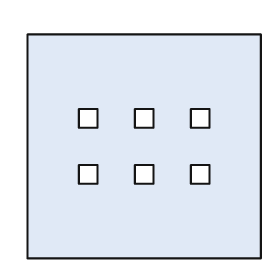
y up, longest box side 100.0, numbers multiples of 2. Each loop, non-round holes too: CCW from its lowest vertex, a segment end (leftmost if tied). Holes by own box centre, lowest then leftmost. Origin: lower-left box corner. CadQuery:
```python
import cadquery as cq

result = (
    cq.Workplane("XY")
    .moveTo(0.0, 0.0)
    .lineTo(100.0, 0.0)
    .lineTo(100.0, 96.0)
    .lineTo(0.0, 96.0)
    .close()
    .moveTo(22.0, 32.0)
    .lineTo(30.0, 32.0)
    .lineTo(30.0, 40.0)
    .lineTo(22.0, 40.0)
    .close()
    .moveTo(46.0, 32.0)
    .lineTo(54.0, 32.0)
    .lineTo(54.0, 40.0)
    .lineTo(46.0, 40.0)
    .close()
    .moveTo(70.0, 32.0)
    .lineTo(78.0, 32.0)
    .lineTo(78.0, 40.0)
    .lineTo(70.0, 40.0)
    .close()
    .moveTo(22.0, 56.0)
    .lineTo(30.0, 56.0)
    .lineTo(30.0, 64.0)
    .lineTo(22.0, 64.0)
    .close()
    .moveTo(46.0, 56.0)
    .lineTo(54.0, 56.0)
    .lineTo(54.0, 64.0)
    .lineTo(46.0, 64.0)
    .close()
    .moveTo(70.0, 56.0)
    .lineTo(78.0, 56.0)
    .lineTo(78.0, 64.0)
    .lineTo(70.0, 64.0)
    .close()
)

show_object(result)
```